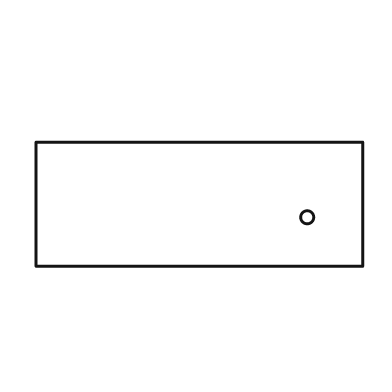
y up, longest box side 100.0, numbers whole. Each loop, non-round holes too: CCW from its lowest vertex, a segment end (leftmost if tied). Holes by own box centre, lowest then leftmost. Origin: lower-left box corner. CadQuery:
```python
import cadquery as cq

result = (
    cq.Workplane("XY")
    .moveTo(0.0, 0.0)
    .lineTo(100.0, 0.0)
    .lineTo(100.0, 38.0)
    .lineTo(0.0, 38.0)
    .close()
    .moveTo(83.0, 15.0)
    .circle(2.0)
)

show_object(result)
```